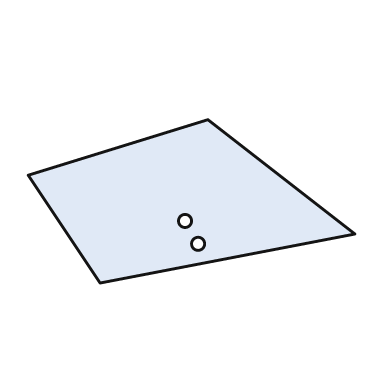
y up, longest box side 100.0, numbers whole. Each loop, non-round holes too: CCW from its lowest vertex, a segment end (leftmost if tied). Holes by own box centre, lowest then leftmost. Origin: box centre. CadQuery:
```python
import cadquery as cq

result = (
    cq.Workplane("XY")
    .moveTo(-28.0, -25.0)
    .lineTo(50.0, -10.0)
    .lineTo(5.0, 25.0)
    .lineTo(-50.0, 8.0)
    .close()
    .moveTo(2.0, -13.0)
    .circle(2.0)
    .moveTo(-2.0, -6.0)
    .circle(2.0)
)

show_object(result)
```